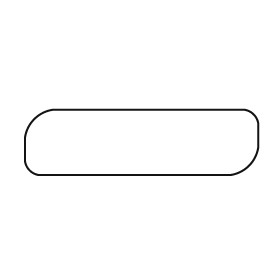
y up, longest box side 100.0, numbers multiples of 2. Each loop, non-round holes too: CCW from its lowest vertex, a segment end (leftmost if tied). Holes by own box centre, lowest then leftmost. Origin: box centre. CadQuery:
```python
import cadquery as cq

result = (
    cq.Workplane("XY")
    .moveTo(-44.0, -14.0)
    .lineTo(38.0, -14.0)
    .threePointArc((46.0, -10.0), (50.0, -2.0))
    .lineTo(50.0, 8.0)
    .threePointArc((48.0, 12.0), (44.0, 14.0))
    .lineTo(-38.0, 14.0)
    .threePointArc((-46.0, 10.0), (-50.0, 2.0))
    .lineTo(-50.0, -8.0)
    .threePointArc((-48.0, -12.0), (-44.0, -14.0))
    .close()
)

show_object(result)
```